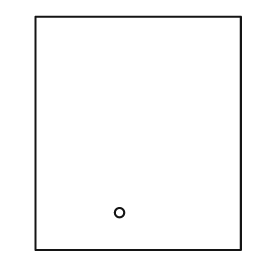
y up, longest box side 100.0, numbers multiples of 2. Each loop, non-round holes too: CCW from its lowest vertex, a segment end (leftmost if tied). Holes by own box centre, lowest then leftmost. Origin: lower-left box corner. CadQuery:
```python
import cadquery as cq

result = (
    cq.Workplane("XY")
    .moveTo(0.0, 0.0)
    .lineTo(88.0, 0.0)
    .lineTo(88.0, 100.0)
    .lineTo(0.0, 100.0)
    .close()
    .moveTo(36.0, 16.0)
    .circle(2.0)
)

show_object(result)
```